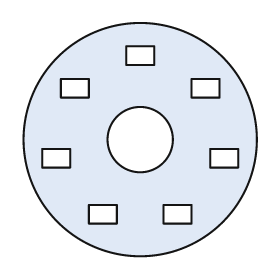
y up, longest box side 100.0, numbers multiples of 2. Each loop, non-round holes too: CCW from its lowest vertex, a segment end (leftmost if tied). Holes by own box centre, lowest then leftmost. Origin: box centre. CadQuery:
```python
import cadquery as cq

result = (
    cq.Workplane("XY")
    .moveTo(0.0, 0.0)
    .circle(50.0)
    .moveTo(-22.0, -36.0)
    .lineTo(-10.0, -36.0)
    .lineTo(-10.0, -28.0)
    .lineTo(-22.0, -28.0)
    .close()
    .moveTo(10.0, -36.0)
    .lineTo(22.0, -36.0)
    .lineTo(22.0, -28.0)
    .lineTo(10.0, -28.0)
    .close()
    .moveTo(-42.0, -12.0)
    .lineTo(-30.0, -12.0)
    .lineTo(-30.0, -4.0)
    .lineTo(-42.0, -4.0)
    .close()
    .moveTo(30.0, -12.0)
    .lineTo(42.0, -12.0)
    .lineTo(42.0, -4.0)
    .lineTo(30.0, -4.0)
    .close()
    .moveTo(0.0, 0.0)
    .circle(14.0)
    .moveTo(-34.0, 18.0)
    .lineTo(-22.0, 18.0)
    .lineTo(-22.0, 26.0)
    .lineTo(-34.0, 26.0)
    .close()
    .moveTo(22.0, 18.0)
    .lineTo(34.0, 18.0)
    .lineTo(34.0, 26.0)
    .lineTo(22.0, 26.0)
    .close()
    .moveTo(-6.0, 32.0)
    .lineTo(6.0, 32.0)
    .lineTo(6.0, 40.0)
    .lineTo(-6.0, 40.0)
    .close()
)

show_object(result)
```